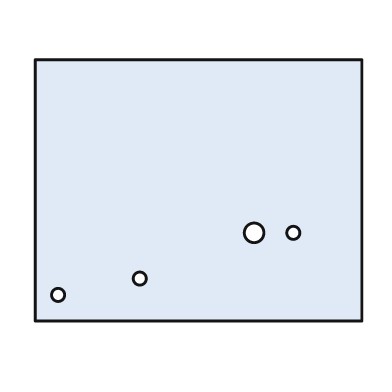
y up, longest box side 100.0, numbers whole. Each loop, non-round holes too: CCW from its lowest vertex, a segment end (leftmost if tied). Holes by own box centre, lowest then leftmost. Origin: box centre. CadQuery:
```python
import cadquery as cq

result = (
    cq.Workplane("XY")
    .moveTo(-50.0, -40.0)
    .lineTo(50.0, -40.0)
    .lineTo(50.0, 40.0)
    .lineTo(-50.0, 40.0)
    .close()
    .moveTo(-43.0, -32.0)
    .circle(2.0)
    .moveTo(-18.0, -27.0)
    .circle(2.0)
    .moveTo(17.0, -13.0)
    .circle(3.0)
    .moveTo(29.0, -13.0)
    .circle(2.0)
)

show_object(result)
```